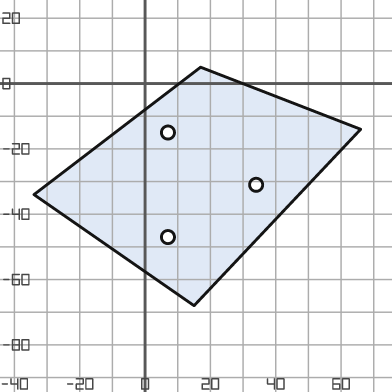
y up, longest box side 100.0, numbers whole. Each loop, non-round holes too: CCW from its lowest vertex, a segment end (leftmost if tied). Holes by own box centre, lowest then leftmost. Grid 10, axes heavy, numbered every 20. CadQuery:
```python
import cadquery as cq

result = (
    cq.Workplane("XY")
    .moveTo(15.0, -68.0)
    .lineTo(66.0, -14.0)
    .lineTo(17.0, 5.0)
    .lineTo(-34.0, -34.0)
    .close()
    .moveTo(7.0, -47.0)
    .circle(2.0)
    .moveTo(34.0, -31.0)
    .circle(2.0)
    .moveTo(7.0, -15.0)
    .circle(2.0)
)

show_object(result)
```